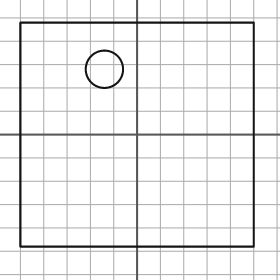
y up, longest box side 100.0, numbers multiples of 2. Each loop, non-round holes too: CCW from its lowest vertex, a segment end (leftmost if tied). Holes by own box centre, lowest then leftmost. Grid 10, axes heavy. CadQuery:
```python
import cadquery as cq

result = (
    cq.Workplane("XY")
    .moveTo(-50.0, -48.0)
    .lineTo(50.0, -48.0)
    .lineTo(50.0, 48.0)
    .lineTo(-50.0, 48.0)
    .close()
    .moveTo(-14.0, 28.0)
    .circle(8.0)
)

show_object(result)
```